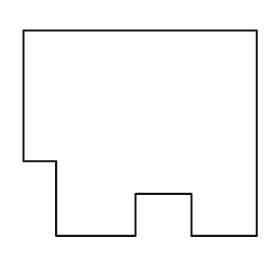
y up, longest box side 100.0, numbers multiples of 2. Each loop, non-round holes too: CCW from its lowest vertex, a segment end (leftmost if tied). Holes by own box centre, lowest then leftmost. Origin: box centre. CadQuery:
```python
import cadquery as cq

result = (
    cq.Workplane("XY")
    .moveTo(-36.0, -44.0)
    .lineTo(-2.0, -44.0)
    .lineTo(-2.0, -26.0)
    .lineTo(22.0, -26.0)
    .lineTo(22.0, -44.0)
    .lineTo(50.0, -44.0)
    .lineTo(50.0, 44.0)
    .lineTo(-50.0, 44.0)
    .lineTo(-50.0, -12.0)
    .lineTo(-36.0, -12.0)
    .close()
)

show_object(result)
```